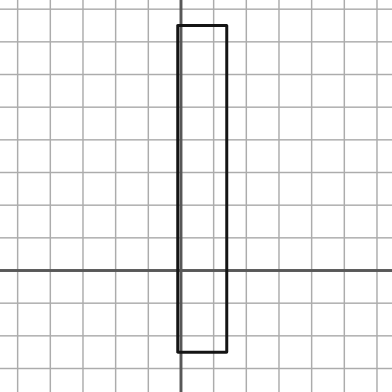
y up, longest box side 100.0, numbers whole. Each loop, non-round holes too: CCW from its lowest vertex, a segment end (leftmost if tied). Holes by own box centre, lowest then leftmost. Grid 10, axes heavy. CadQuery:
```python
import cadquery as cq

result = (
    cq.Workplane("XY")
    .moveTo(-1.0, -25.0)
    .lineTo(14.0, -25.0)
    .lineTo(14.0, 75.0)
    .lineTo(-1.0, 75.0)
    .close()
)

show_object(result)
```